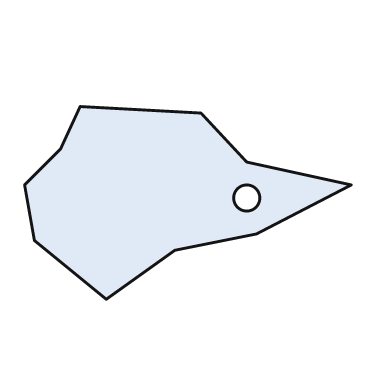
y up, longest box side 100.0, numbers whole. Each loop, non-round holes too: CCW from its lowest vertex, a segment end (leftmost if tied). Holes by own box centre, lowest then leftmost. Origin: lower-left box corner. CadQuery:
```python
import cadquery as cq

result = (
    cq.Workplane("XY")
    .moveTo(25.0, 0.0)
    .lineTo(46.0, 15.0)
    .lineTo(71.0, 20.0)
    .lineTo(100.0, 35.0)
    .lineTo(68.0, 42.0)
    .lineTo(54.0, 57.0)
    .lineTo(17.0, 59.0)
    .lineTo(11.0, 46.0)
    .lineTo(0.0, 35.0)
    .lineTo(3.0, 18.0)
    .close()
    .moveTo(68.0, 31.0)
    .circle(4.0)
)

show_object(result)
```